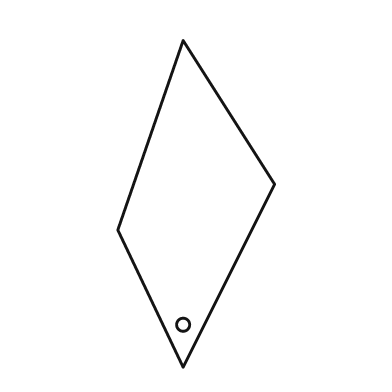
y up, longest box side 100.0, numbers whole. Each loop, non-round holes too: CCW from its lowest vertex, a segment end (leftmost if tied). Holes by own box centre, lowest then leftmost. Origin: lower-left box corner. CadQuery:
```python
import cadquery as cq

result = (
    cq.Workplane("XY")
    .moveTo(20.0, 0.0)
    .lineTo(48.0, 56.0)
    .lineTo(20.0, 100.0)
    .lineTo(0.0, 42.0)
    .close()
    .moveTo(20.0, 13.0)
    .circle(2.0)
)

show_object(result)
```